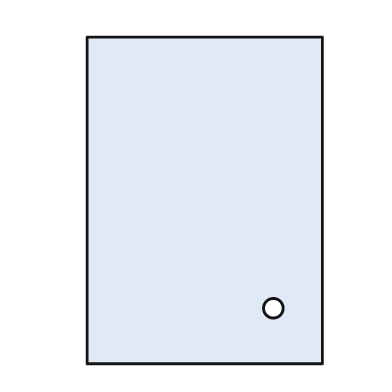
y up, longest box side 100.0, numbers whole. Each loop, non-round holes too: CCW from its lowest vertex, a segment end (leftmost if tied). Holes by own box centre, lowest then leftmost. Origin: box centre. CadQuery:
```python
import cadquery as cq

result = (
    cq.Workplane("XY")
    .moveTo(-36.0, -50.0)
    .lineTo(36.0, -50.0)
    .lineTo(36.0, 50.0)
    .lineTo(-36.0, 50.0)
    .close()
    .moveTo(21.0, -33.0)
    .circle(3.0)
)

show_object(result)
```